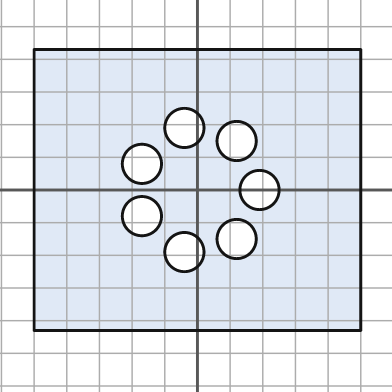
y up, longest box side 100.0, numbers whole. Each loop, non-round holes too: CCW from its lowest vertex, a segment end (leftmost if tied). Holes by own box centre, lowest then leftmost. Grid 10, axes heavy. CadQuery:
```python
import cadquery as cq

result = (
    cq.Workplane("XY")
    .moveTo(-50.0, -43.0)
    .lineTo(50.0, -43.0)
    .lineTo(50.0, 43.0)
    .lineTo(-50.0, 43.0)
    .close()
    .moveTo(-4.0, -19.0)
    .circle(6.0)
    .moveTo(12.0, -15.0)
    .circle(6.0)
    .moveTo(-17.0, -8.0)
    .circle(6.0)
    .moveTo(19.0, 0.0)
    .circle(6.0)
    .moveTo(-17.0, 8.0)
    .circle(6.0)
    .moveTo(12.0, 15.0)
    .circle(6.0)
    .moveTo(-4.0, 19.0)
    .circle(6.0)
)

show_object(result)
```